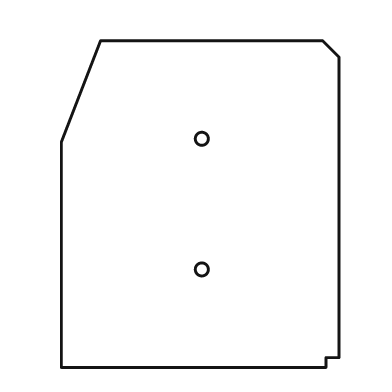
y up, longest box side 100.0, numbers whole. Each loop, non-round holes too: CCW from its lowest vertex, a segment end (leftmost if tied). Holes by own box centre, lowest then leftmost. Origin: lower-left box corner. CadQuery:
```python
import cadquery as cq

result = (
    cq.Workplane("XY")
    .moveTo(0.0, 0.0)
    .lineTo(81.0, 0.0)
    .lineTo(81.0, 3.0)
    .lineTo(85.0, 3.0)
    .lineTo(85.0, 95.0)
    .lineTo(80.0, 100.0)
    .lineTo(12.0, 100.0)
    .lineTo(0.0, 69.0)
    .close()
    .moveTo(43.0, 30.0)
    .circle(2.0)
    .moveTo(43.0, 70.0)
    .circle(2.0)
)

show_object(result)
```